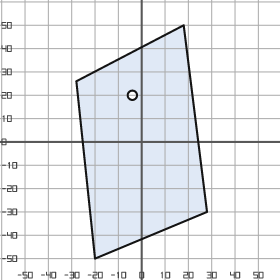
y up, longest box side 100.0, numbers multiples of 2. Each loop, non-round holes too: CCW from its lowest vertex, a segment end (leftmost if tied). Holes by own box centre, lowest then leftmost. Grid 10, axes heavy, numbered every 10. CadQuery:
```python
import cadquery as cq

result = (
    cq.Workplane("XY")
    .moveTo(-20.0, -50.0)
    .lineTo(28.0, -30.0)
    .lineTo(18.0, 50.0)
    .lineTo(-28.0, 26.0)
    .close()
    .moveTo(-4.0, 20.0)
    .circle(2.0)
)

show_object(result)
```